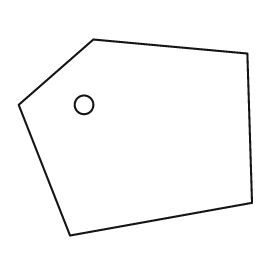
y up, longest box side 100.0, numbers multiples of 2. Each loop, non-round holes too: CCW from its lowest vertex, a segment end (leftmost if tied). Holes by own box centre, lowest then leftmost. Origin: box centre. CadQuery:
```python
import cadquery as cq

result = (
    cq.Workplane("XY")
    .moveTo(-28.0, -42.0)
    .lineTo(50.0, -28.0)
    .lineTo(48.0, 36.0)
    .lineTo(-18.0, 42.0)
    .lineTo(-50.0, 14.0)
    .close()
    .moveTo(-22.0, 14.0)
    .circle(4.0)
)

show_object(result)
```